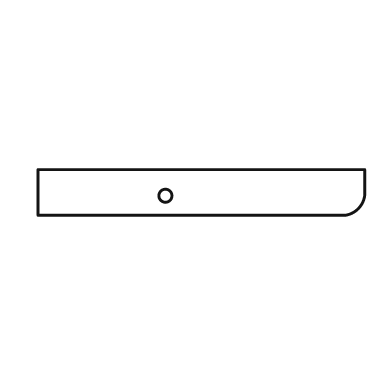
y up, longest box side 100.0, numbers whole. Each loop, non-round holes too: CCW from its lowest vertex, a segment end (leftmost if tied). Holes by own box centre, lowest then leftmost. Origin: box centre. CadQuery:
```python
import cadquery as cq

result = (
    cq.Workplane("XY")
    .moveTo(-50.0, -7.0)
    .lineTo(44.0, -7.0)
    .threePointArc((48.0, -5.0), (50.0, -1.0))
    .lineTo(50.0, 7.0)
    .lineTo(-50.0, 7.0)
    .close()
    .moveTo(-11.0, -1.0)
    .circle(2.0)
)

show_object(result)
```